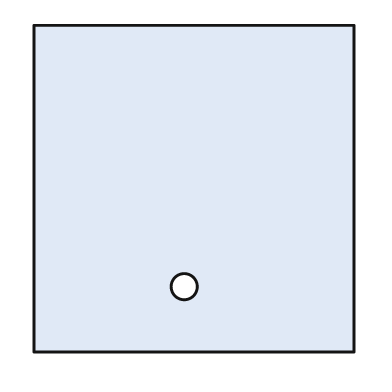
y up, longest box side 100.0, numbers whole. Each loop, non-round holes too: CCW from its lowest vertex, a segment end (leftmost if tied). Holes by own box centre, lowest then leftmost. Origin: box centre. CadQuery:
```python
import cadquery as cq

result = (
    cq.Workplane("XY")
    .moveTo(-49.0, -50.0)
    .lineTo(49.0, -50.0)
    .lineTo(49.0, 50.0)
    .lineTo(-49.0, 50.0)
    .close()
    .moveTo(-3.0, -30.0)
    .circle(4.0)
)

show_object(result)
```